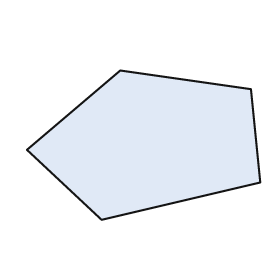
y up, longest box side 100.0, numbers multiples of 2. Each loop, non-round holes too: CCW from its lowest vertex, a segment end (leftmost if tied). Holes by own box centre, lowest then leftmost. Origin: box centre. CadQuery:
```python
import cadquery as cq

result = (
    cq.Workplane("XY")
    .moveTo(-18.0, -32.0)
    .lineTo(50.0, -16.0)
    .lineTo(46.0, 24.0)
    .lineTo(-10.0, 32.0)
    .lineTo(-50.0, -2.0)
    .close()
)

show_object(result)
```